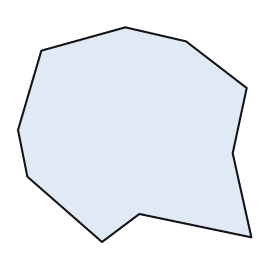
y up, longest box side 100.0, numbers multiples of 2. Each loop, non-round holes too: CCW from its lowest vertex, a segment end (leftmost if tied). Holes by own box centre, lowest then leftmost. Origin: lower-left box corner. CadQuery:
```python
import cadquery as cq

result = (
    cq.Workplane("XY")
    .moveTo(36.0, 0.0)
    .lineTo(52.0, 12.0)
    .lineTo(100.0, 2.0)
    .lineTo(92.0, 38.0)
    .lineTo(98.0, 66.0)
    .lineTo(72.0, 86.0)
    .lineTo(46.0, 92.0)
    .lineTo(10.0, 82.0)
    .lineTo(0.0, 48.0)
    .lineTo(4.0, 28.0)
    .close()
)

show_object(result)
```